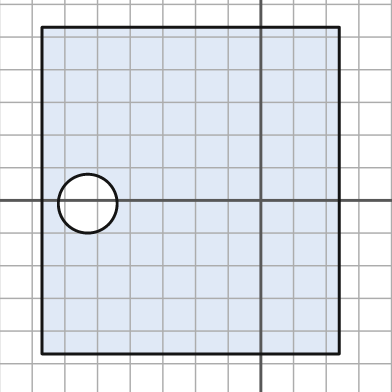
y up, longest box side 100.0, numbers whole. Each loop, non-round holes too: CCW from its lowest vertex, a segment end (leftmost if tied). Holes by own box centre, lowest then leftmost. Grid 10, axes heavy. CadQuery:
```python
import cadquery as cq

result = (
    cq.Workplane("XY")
    .moveTo(-67.0, -47.0)
    .lineTo(24.0, -47.0)
    .lineTo(24.0, 53.0)
    .lineTo(-67.0, 53.0)
    .close()
    .moveTo(-53.0, -1.0)
    .circle(9.0)
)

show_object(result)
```